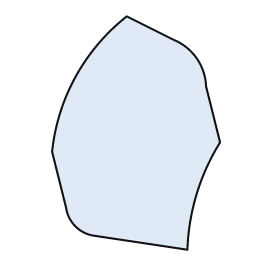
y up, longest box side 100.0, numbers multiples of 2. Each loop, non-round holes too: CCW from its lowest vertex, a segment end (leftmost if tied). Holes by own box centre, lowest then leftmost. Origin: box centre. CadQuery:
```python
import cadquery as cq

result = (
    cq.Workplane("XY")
    .moveTo(22.0, -50.0)
    .threePointArc((26.0, -26.0), (36.0, -4.0))
    .lineTo(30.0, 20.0)
    .threePointArc((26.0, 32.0), (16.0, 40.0))
    .lineTo(-4.0, 50.0)
    .threePointArc((-26.0, 24.0), (-36.0, -8.0))
    .lineTo(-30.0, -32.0)
    .threePointArc((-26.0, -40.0), (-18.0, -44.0))
    .close()
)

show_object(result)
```